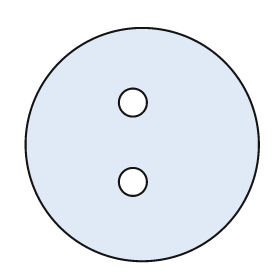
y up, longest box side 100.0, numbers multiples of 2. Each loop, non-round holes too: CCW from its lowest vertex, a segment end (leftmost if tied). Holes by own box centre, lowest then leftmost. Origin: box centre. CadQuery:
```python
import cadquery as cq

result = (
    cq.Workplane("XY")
    .moveTo(0.0, 0.0)
    .circle(50.0)
    .moveTo(-4.0, -16.0)
    .circle(6.0)
    .moveTo(-4.0, 18.0)
    .circle(6.0)
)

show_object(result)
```